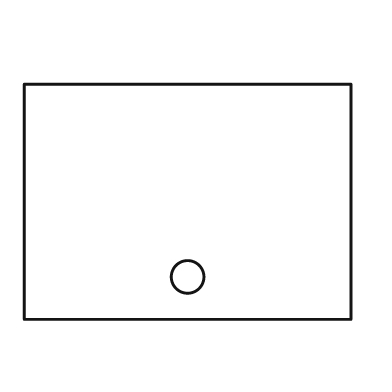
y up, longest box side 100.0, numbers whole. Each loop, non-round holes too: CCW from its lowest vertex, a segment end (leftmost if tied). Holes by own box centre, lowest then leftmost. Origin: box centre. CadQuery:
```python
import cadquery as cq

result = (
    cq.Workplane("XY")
    .moveTo(-50.0, -36.0)
    .lineTo(50.0, -36.0)
    .lineTo(50.0, 36.0)
    .lineTo(-50.0, 36.0)
    .close()
    .moveTo(0.0, -23.0)
    .circle(5.0)
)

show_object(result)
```